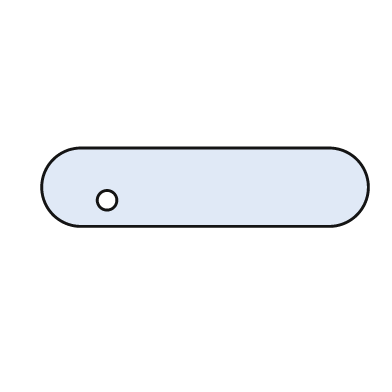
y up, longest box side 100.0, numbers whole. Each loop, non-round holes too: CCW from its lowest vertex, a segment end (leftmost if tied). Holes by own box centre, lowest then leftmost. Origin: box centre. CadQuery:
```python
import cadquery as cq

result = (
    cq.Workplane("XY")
    .moveTo(-38.0, -12.0)
    .lineTo(38.0, -12.0)
    .threePointArc((50.0, 0.0), (38.0, 12.0))
    .lineTo(-38.0, 12.0)
    .threePointArc((-50.0, 0.0), (-38.0, -12.0))
    .close()
    .moveTo(-30.0, -4.0)
    .circle(3.0)
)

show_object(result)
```